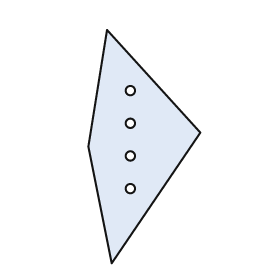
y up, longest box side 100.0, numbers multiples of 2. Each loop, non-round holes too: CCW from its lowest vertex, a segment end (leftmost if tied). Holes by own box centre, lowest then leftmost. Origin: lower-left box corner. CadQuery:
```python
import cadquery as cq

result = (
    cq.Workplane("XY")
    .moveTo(10.0, 0.0)
    .lineTo(48.0, 56.0)
    .lineTo(8.0, 100.0)
    .lineTo(0.0, 50.0)
    .close()
    .moveTo(18.0, 32.0)
    .circle(2.0)
    .moveTo(18.0, 46.0)
    .circle(2.0)
    .moveTo(18.0, 60.0)
    .circle(2.0)
    .moveTo(18.0, 74.0)
    .circle(2.0)
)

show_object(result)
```